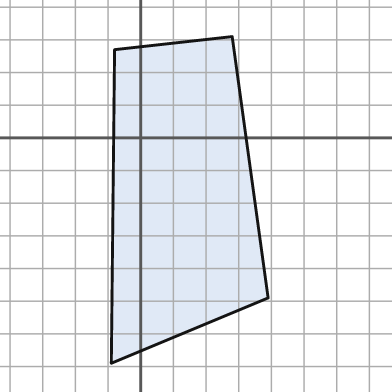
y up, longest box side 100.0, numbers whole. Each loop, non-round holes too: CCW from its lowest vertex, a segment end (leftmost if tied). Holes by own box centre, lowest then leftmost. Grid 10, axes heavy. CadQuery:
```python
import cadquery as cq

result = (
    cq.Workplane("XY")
    .moveTo(-9.0, -69.0)
    .lineTo(39.0, -49.0)
    .lineTo(28.0, 31.0)
    .lineTo(-8.0, 27.0)
    .close()
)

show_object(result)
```